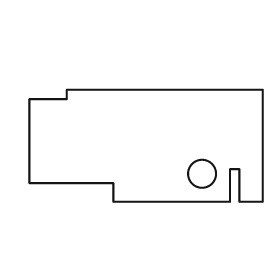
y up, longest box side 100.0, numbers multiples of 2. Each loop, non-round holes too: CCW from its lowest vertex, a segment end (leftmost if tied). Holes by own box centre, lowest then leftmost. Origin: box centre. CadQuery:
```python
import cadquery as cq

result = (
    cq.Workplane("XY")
    .moveTo(-14.0, -24.0)
    .lineTo(36.0, -24.0)
    .lineTo(36.0, -10.0)
    .lineTo(40.0, -10.0)
    .lineTo(40.0, -24.0)
    .lineTo(50.0, -24.0)
    .lineTo(50.0, 24.0)
    .lineTo(-34.0, 24.0)
    .lineTo(-34.0, 20.0)
    .lineTo(-50.0, 20.0)
    .lineTo(-50.0, -16.0)
    .lineTo(-14.0, -16.0)
    .close()
    .moveTo(24.0, -12.0)
    .circle(6.0)
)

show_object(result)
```